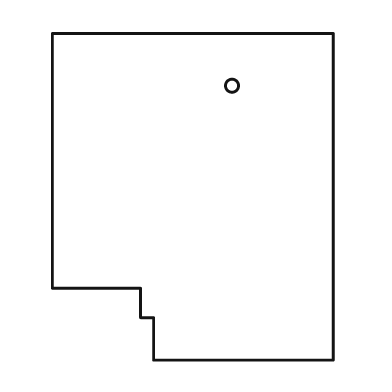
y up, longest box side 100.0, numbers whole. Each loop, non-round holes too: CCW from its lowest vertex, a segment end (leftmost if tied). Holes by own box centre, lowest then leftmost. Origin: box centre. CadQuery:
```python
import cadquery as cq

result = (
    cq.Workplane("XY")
    .moveTo(-12.0, -50.0)
    .lineTo(43.0, -50.0)
    .lineTo(43.0, 50.0)
    .lineTo(-43.0, 50.0)
    .lineTo(-43.0, -28.0)
    .lineTo(-16.0, -28.0)
    .lineTo(-16.0, -37.0)
    .lineTo(-12.0, -37.0)
    .close()
    .moveTo(12.0, 34.0)
    .circle(2.0)
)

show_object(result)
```